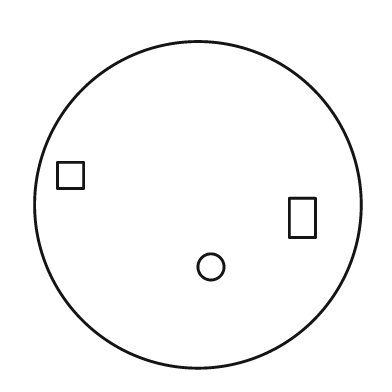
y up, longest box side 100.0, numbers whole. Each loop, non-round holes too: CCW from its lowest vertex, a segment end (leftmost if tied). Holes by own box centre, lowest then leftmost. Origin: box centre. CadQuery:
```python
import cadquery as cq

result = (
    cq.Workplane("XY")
    .moveTo(0.0, 0.0)
    .circle(50.0)
    .moveTo(4.0, -19.0)
    .circle(4.0)
    .moveTo(28.0, -10.0)
    .lineTo(36.0, -10.0)
    .lineTo(36.0, 2.0)
    .lineTo(28.0, 2.0)
    .close()
    .moveTo(-43.0, 5.0)
    .lineTo(-35.0, 5.0)
    .lineTo(-35.0, 13.0)
    .lineTo(-43.0, 13.0)
    .close()
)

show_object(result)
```